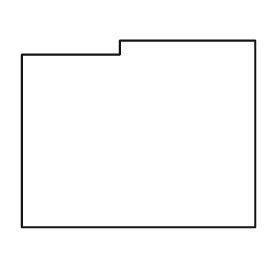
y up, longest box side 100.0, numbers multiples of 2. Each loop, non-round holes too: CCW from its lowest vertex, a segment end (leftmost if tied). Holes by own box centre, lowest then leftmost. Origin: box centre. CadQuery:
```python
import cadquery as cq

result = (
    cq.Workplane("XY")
    .moveTo(-50.0, -40.0)
    .lineTo(50.0, -40.0)
    .lineTo(50.0, 40.0)
    .lineTo(-8.0, 40.0)
    .lineTo(-8.0, 34.0)
    .lineTo(-50.0, 34.0)
    .close()
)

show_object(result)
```